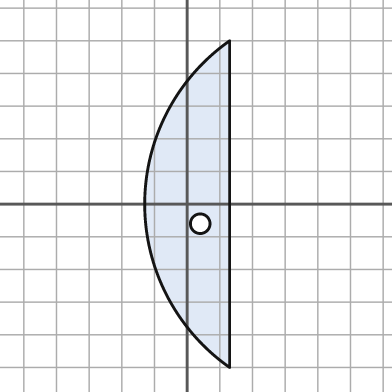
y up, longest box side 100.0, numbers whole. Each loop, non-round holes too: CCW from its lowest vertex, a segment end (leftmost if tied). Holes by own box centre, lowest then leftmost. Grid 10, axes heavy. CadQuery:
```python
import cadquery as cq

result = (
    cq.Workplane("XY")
    .moveTo(13.0, -50.0)
    .lineTo(13.0, 50.0)
    .threePointArc((-13.0, 0.0), (13.0, -50.0))
    .close()
    .moveTo(4.0, -6.0)
    .circle(3.0)
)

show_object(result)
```